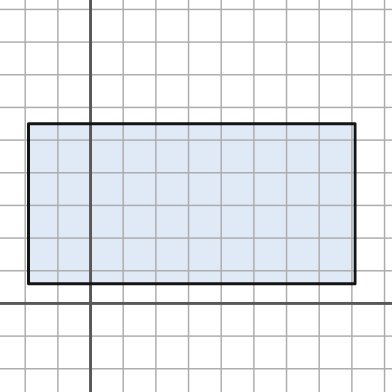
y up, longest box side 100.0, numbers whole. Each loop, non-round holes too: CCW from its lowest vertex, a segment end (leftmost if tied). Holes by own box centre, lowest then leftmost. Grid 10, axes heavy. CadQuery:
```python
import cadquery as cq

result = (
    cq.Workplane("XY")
    .moveTo(-19.0, 6.0)
    .lineTo(81.0, 6.0)
    .lineTo(81.0, 55.0)
    .lineTo(-19.0, 55.0)
    .close()
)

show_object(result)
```